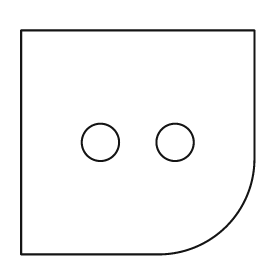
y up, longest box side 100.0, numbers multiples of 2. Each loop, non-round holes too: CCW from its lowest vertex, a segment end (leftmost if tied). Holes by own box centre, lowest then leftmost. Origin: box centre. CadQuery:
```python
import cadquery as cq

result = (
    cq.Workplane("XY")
    .moveTo(-50.0, -48.0)
    .lineTo(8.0, -48.0)
    .threePointArc((38.0, -36.0), (50.0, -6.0))
    .lineTo(50.0, 48.0)
    .lineTo(-50.0, 48.0)
    .close()
    .moveTo(-16.0, 0.0)
    .circle(8.0)
    .moveTo(16.0, 0.0)
    .circle(8.0)
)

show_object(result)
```